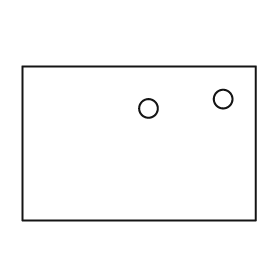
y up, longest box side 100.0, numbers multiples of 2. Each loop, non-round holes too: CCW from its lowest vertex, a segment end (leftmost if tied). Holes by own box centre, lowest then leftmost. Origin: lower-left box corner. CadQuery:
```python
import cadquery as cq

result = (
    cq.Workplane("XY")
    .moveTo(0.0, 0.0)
    .lineTo(100.0, 0.0)
    .lineTo(100.0, 66.0)
    .lineTo(0.0, 66.0)
    .close()
    .moveTo(54.0, 48.0)
    .circle(4.0)
    .moveTo(86.0, 52.0)
    .circle(4.0)
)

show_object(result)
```